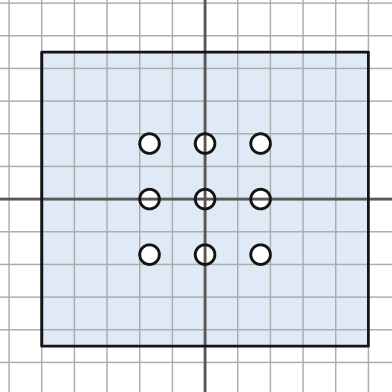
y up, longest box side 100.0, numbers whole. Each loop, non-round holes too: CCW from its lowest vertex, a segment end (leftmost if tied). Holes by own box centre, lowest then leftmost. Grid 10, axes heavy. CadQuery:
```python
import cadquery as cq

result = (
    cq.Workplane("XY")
    .moveTo(-50.0, -45.0)
    .lineTo(50.0, -45.0)
    .lineTo(50.0, 45.0)
    .lineTo(-50.0, 45.0)
    .close()
    .moveTo(-17.0, -17.0)
    .circle(3.0)
    .moveTo(0.0, -17.0)
    .circle(3.0)
    .moveTo(17.0, -17.0)
    .circle(3.0)
    .moveTo(-17.0, 0.0)
    .circle(3.0)
    .moveTo(0.0, 0.0)
    .circle(3.0)
    .moveTo(17.0, 0.0)
    .circle(3.0)
    .moveTo(-17.0, 17.0)
    .circle(3.0)
    .moveTo(0.0, 17.0)
    .circle(3.0)
    .moveTo(17.0, 17.0)
    .circle(3.0)
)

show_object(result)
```